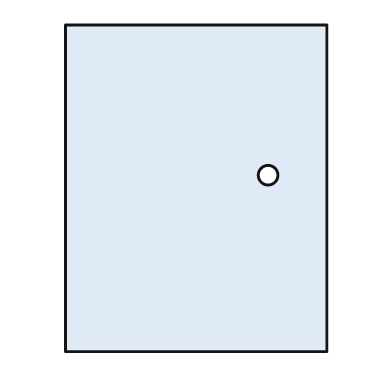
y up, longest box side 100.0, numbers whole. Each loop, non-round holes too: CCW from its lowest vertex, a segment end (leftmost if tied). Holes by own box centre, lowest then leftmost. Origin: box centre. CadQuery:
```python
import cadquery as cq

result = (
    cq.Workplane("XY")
    .moveTo(-40.0, -50.0)
    .lineTo(40.0, -50.0)
    .lineTo(40.0, 50.0)
    .lineTo(-40.0, 50.0)
    .close()
    .moveTo(22.0, 4.0)
    .circle(3.0)
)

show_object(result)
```